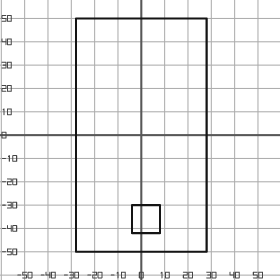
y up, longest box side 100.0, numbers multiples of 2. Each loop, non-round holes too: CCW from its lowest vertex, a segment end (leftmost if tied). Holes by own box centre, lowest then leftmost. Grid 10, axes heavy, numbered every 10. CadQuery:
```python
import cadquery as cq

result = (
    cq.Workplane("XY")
    .moveTo(-28.0, -50.0)
    .lineTo(28.0, -50.0)
    .lineTo(28.0, 50.0)
    .lineTo(-28.0, 50.0)
    .close()
    .moveTo(-4.0, -42.0)
    .lineTo(8.0, -42.0)
    .lineTo(8.0, -30.0)
    .lineTo(-4.0, -30.0)
    .close()
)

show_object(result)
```